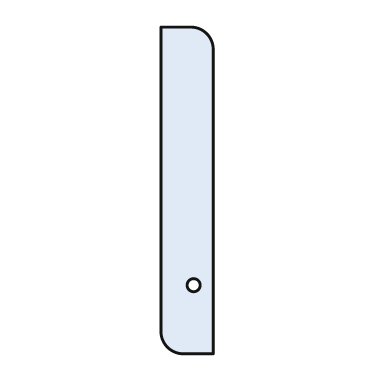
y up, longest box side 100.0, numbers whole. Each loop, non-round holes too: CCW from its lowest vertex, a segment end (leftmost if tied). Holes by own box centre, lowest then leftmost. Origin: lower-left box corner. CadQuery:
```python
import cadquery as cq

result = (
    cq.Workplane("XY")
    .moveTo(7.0, 0.0)
    .lineTo(16.0, 0.0)
    .lineTo(16.0, 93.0)
    .threePointArc((14.0, 98.0), (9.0, 100.0))
    .lineTo(0.0, 100.0)
    .lineTo(0.0, 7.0)
    .threePointArc((2.0, 2.0), (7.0, 0.0))
    .close()
    .moveTo(10.0, 21.0)
    .circle(2.0)
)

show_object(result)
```